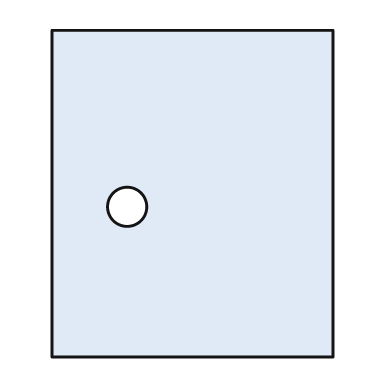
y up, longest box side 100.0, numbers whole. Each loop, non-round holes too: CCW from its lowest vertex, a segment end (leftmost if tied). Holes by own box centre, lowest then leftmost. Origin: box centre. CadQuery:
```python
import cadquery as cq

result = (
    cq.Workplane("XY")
    .moveTo(-43.0, -50.0)
    .lineTo(43.0, -50.0)
    .lineTo(43.0, 50.0)
    .lineTo(-43.0, 50.0)
    .close()
    .moveTo(-20.0, -4.0)
    .circle(6.0)
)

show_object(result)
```